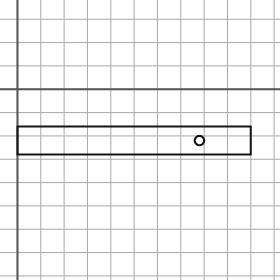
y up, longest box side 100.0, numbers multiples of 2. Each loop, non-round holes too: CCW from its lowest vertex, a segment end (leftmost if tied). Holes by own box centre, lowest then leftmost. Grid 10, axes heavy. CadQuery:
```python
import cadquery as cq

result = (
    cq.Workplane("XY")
    .moveTo(0.0, -28.0)
    .lineTo(100.0, -28.0)
    .lineTo(100.0, -16.0)
    .lineTo(0.0, -16.0)
    .close()
    .moveTo(78.0, -22.0)
    .circle(2.0)
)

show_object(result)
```